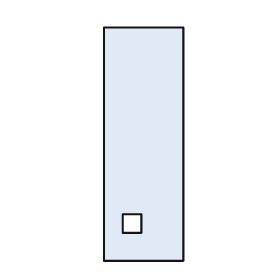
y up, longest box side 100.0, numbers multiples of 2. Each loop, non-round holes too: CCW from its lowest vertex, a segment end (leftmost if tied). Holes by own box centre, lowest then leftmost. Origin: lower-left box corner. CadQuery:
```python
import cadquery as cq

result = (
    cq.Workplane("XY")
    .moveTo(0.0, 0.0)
    .lineTo(34.0, 0.0)
    .lineTo(34.0, 100.0)
    .lineTo(0.0, 100.0)
    .close()
    .moveTo(8.0, 12.0)
    .lineTo(16.0, 12.0)
    .lineTo(16.0, 20.0)
    .lineTo(8.0, 20.0)
    .close()
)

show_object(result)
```